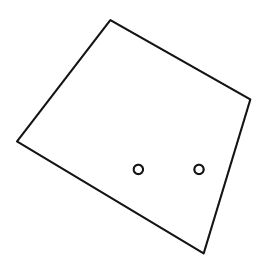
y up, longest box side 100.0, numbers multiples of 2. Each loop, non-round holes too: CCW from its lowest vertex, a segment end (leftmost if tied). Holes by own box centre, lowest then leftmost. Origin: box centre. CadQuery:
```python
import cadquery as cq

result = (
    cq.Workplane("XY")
    .moveTo(30.0, -50.0)
    .lineTo(50.0, 16.0)
    .lineTo(-10.0, 50.0)
    .lineTo(-50.0, -2.0)
    .close()
    .moveTo(2.0, -14.0)
    .circle(2.0)
    .moveTo(28.0, -14.0)
    .circle(2.0)
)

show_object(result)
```